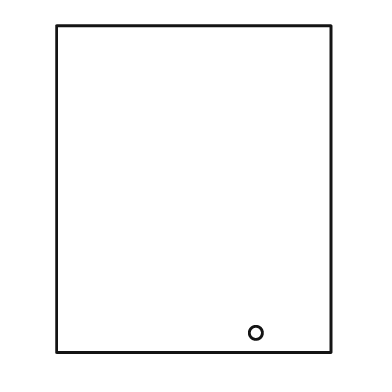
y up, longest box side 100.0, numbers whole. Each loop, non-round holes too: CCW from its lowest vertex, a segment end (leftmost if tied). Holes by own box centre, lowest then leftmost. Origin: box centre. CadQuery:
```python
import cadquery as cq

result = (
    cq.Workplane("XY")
    .moveTo(-42.0, -50.0)
    .lineTo(42.0, -50.0)
    .lineTo(42.0, 50.0)
    .lineTo(-42.0, 50.0)
    .close()
    .moveTo(19.0, -44.0)
    .circle(2.0)
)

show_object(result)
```